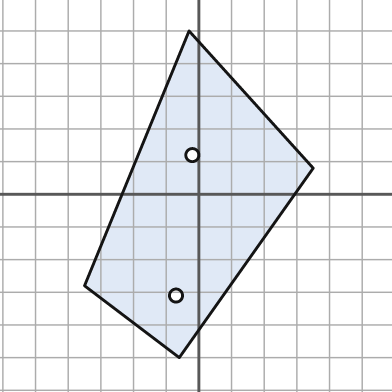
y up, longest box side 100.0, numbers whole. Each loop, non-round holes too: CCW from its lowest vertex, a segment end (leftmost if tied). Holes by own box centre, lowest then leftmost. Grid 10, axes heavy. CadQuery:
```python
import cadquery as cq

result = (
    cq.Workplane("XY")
    .moveTo(-6.0, -50.0)
    .lineTo(35.0, 8.0)
    .lineTo(-3.0, 50.0)
    .lineTo(-35.0, -28.0)
    .close()
    .moveTo(-7.0, -31.0)
    .circle(2.0)
    .moveTo(-2.0, 12.0)
    .circle(2.0)
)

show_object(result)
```